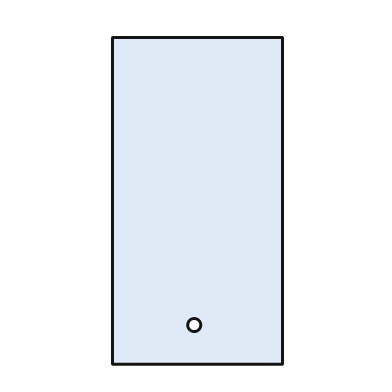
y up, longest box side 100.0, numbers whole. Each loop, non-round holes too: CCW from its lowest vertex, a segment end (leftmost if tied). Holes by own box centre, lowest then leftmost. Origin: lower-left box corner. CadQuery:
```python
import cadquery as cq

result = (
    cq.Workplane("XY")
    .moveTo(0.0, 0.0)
    .lineTo(52.0, 0.0)
    .lineTo(52.0, 100.0)
    .lineTo(0.0, 100.0)
    .close()
    .moveTo(25.0, 12.0)
    .circle(2.0)
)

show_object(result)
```